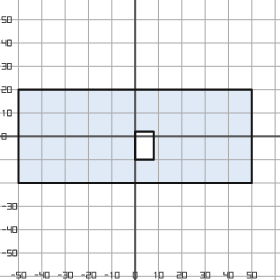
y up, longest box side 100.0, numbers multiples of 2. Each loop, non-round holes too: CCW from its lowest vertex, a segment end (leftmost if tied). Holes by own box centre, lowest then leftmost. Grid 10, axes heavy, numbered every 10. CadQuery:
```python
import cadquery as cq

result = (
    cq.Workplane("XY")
    .moveTo(-50.0, -20.0)
    .lineTo(50.0, -20.0)
    .lineTo(50.0, 20.0)
    .lineTo(-50.0, 20.0)
    .close()
    .moveTo(0.0, -10.0)
    .lineTo(8.0, -10.0)
    .lineTo(8.0, 2.0)
    .lineTo(0.0, 2.0)
    .close()
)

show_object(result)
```